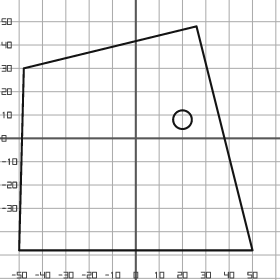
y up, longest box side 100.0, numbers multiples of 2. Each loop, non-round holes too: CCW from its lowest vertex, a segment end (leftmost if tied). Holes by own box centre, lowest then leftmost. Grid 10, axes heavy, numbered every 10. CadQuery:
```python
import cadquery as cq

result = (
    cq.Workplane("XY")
    .moveTo(-50.0, -48.0)
    .lineTo(50.0, -48.0)
    .lineTo(26.0, 48.0)
    .lineTo(-48.0, 30.0)
    .close()
    .moveTo(20.0, 8.0)
    .circle(4.0)
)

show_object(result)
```